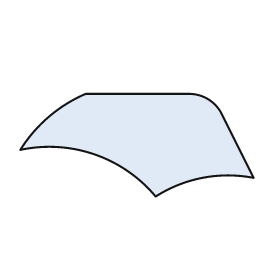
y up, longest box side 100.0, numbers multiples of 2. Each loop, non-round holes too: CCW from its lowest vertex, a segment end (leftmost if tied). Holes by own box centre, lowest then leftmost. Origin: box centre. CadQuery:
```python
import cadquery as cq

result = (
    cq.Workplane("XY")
    .moveTo(8.0, -22.0)
    .threePointArc((28.0, -14.0), (50.0, -14.0))
    .lineTo(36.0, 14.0)
    .threePointArc((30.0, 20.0), (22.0, 22.0))
    .lineTo(-22.0, 22.0)
    .threePointArc((-38.0, 12.0), (-50.0, -2.0))
    .threePointArc((-18.0, -4.0), (8.0, -22.0))
    .close()
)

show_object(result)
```